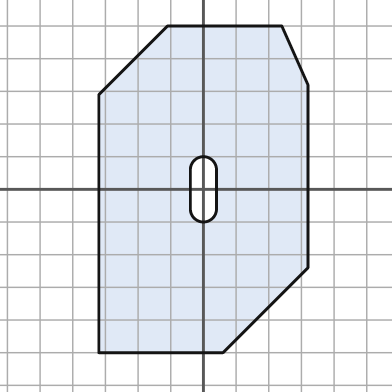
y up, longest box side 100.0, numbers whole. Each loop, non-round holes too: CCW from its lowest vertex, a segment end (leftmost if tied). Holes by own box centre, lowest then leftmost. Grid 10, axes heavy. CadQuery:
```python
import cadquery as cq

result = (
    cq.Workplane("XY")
    .moveTo(-32.0, -50.0)
    .lineTo(6.0, -50.0)
    .lineTo(32.0, -24.0)
    .lineTo(32.0, 32.0)
    .lineTo(24.0, 50.0)
    .lineTo(-11.0, 50.0)
    .lineTo(-32.0, 29.0)
    .close()
    .moveTo(-4.0, -6.0)
    .threePointArc((0.0, -10.0), (4.0, -6.0))
    .lineTo(4.0, 6.0)
    .threePointArc((0.0, 10.0), (-4.0, 6.0))
    .close()
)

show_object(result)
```